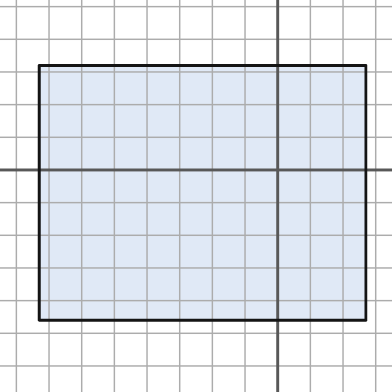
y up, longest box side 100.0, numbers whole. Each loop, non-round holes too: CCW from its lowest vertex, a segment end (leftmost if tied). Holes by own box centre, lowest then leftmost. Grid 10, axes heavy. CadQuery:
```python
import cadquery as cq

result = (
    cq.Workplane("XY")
    .moveTo(-73.0, -46.0)
    .lineTo(27.0, -46.0)
    .lineTo(27.0, 32.0)
    .lineTo(-73.0, 32.0)
    .close()
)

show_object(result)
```